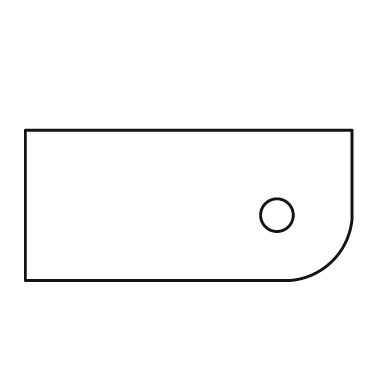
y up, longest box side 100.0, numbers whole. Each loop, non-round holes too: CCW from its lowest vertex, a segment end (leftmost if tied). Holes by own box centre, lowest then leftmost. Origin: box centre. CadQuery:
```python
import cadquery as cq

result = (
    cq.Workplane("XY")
    .moveTo(-50.0, -23.0)
    .lineTo(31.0, -23.0)
    .threePointArc((44.0, -17.0), (50.0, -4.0))
    .lineTo(50.0, 23.0)
    .lineTo(-50.0, 23.0)
    .close()
    .moveTo(27.0, -3.0)
    .circle(5.0)
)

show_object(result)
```